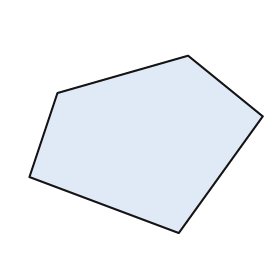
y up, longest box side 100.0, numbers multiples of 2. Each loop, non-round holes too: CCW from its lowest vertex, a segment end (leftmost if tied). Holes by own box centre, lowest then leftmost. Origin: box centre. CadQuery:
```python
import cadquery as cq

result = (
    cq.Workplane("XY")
    .moveTo(14.0, -38.0)
    .lineTo(50.0, 12.0)
    .lineTo(18.0, 38.0)
    .lineTo(-38.0, 22.0)
    .lineTo(-50.0, -14.0)
    .close()
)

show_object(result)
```